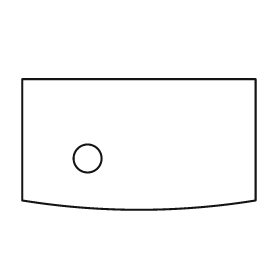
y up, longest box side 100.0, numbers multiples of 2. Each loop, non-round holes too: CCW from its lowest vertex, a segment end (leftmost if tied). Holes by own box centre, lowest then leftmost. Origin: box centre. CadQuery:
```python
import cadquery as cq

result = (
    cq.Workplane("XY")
    .moveTo(-50.0, -24.0)
    .threePointArc((0.0, -28.0), (50.0, -24.0))
    .lineTo(50.0, 28.0)
    .lineTo(-50.0, 28.0)
    .close()
    .moveTo(-22.0, -6.0)
    .circle(6.0)
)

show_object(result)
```